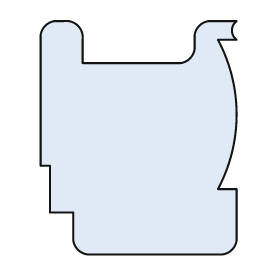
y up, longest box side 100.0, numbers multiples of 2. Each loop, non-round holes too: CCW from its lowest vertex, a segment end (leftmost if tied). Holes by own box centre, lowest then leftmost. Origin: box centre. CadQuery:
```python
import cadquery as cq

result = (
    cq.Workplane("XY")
    .moveTo(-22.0, -50.0)
    .lineTo(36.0, -50.0)
    .threePointArc((40.0, -48.0), (42.0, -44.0))
    .lineTo(42.0, -22.0)
    .lineTo(34.0, -22.0)
    .threePointArc((42.0, 10.0), (34.0, 42.0))
    .lineTo(42.0, 42.0)
    .threePointArc((40.0, 46.0), (42.0, 50.0))
    .lineTo(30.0, 50.0)
    .threePointArc((26.0, 48.0), (24.0, 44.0))
    .lineTo(24.0, 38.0)
    .threePointArc((22.0, 34.0), (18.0, 32.0))
    .lineTo(-24.0, 32.0)
    .lineTo(-24.0, 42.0)
    .threePointArc((-26.0, 48.0), (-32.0, 50.0))
    .lineTo(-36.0, 50.0)
    .threePointArc((-40.0, 48.0), (-42.0, 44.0))
    .lineTo(-42.0, -12.0)
    .lineTo(-38.0, -12.0)
    .lineTo(-38.0, -32.0)
    .lineTo(-28.0, -32.0)
    .lineTo(-28.0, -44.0)
    .threePointArc((-26.0, -48.0), (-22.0, -50.0))
    .close()
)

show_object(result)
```